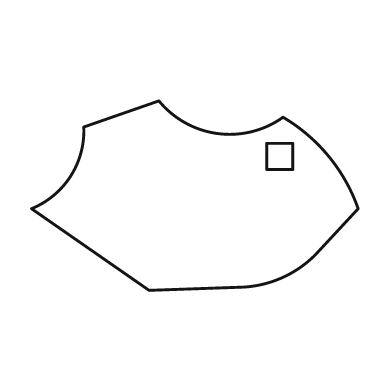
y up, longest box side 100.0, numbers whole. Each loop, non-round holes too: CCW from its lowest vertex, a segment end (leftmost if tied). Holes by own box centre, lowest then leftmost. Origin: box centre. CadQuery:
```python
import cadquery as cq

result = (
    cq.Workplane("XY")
    .moveTo(-14.0, -29.0)
    .lineTo(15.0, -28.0)
    .threePointArc((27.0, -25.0), (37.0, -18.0))
    .lineTo(50.0, -4.0)
    .threePointArc((41.0, 12.0), (27.0, 24.0))
    .threePointArc((7.0, 19.0), (-11.0, 29.0))
    .lineTo(-34.0, 21.0)
    .threePointArc((-38.0, 6.0), (-50.0, -4.0))
    .close()
    .moveTo(22.0, 8.0)
    .lineTo(30.0, 8.0)
    .lineTo(30.0, 16.0)
    .lineTo(22.0, 16.0)
    .close()
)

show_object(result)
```